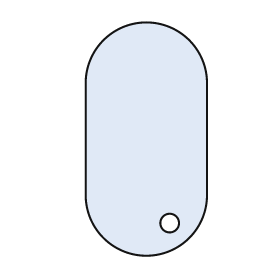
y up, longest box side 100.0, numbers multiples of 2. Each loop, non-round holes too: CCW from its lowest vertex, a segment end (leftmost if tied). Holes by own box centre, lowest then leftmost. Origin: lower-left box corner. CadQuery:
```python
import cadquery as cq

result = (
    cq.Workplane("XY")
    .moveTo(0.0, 26.0)
    .threePointArc((26.0, 0.0), (52.0, 26.0))
    .lineTo(52.0, 74.0)
    .threePointArc((26.0, 100.0), (0.0, 74.0))
    .close()
    .moveTo(36.0, 14.0)
    .circle(4.0)
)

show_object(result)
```